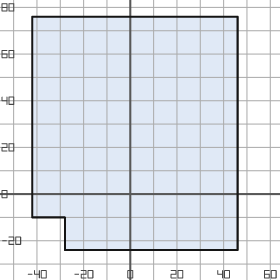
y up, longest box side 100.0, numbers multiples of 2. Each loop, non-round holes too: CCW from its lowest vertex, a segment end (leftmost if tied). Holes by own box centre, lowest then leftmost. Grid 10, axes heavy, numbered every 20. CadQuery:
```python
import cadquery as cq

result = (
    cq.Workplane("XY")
    .moveTo(-28.0, -24.0)
    .lineTo(46.0, -24.0)
    .lineTo(46.0, 76.0)
    .lineTo(-42.0, 76.0)
    .lineTo(-42.0, -10.0)
    .lineTo(-28.0, -10.0)
    .close()
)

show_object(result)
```